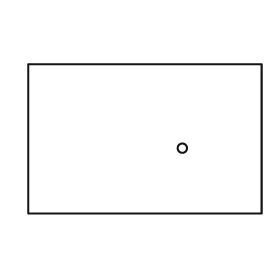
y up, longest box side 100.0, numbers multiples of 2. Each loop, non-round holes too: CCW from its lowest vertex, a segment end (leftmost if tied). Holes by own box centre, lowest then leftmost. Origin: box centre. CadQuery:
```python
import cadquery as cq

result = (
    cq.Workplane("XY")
    .moveTo(-50.0, -32.0)
    .lineTo(50.0, -32.0)
    .lineTo(50.0, 32.0)
    .lineTo(-50.0, 32.0)
    .close()
    .moveTo(16.0, -4.0)
    .circle(2.0)
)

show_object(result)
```